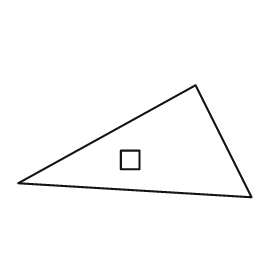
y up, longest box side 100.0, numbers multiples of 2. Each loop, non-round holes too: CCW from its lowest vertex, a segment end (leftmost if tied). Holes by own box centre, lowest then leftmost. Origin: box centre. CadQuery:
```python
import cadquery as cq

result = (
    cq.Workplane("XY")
    .moveTo(50.0, -24.0)
    .lineTo(26.0, 24.0)
    .lineTo(-50.0, -18.0)
    .close()
    .moveTo(-6.0, -12.0)
    .lineTo(2.0, -12.0)
    .lineTo(2.0, -4.0)
    .lineTo(-6.0, -4.0)
    .close()
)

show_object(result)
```